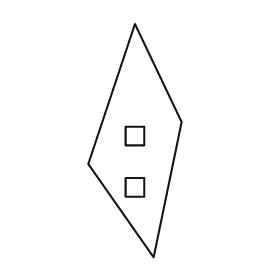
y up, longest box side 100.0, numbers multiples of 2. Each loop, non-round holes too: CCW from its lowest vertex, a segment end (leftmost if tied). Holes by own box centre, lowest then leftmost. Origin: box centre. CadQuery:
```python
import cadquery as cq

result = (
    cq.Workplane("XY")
    .moveTo(8.0, -50.0)
    .lineTo(20.0, 8.0)
    .lineTo(0.0, 50.0)
    .lineTo(-20.0, -10.0)
    .close()
    .moveTo(-4.0, -24.0)
    .lineTo(4.0, -24.0)
    .lineTo(4.0, -16.0)
    .lineTo(-4.0, -16.0)
    .close()
    .moveTo(-4.0, -2.0)
    .lineTo(4.0, -2.0)
    .lineTo(4.0, 6.0)
    .lineTo(-4.0, 6.0)
    .close()
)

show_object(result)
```